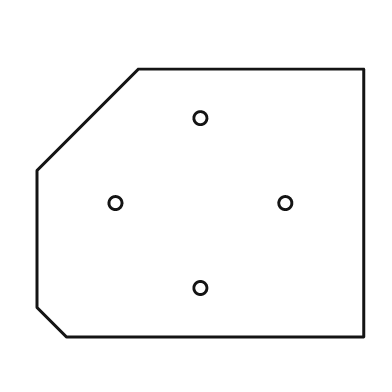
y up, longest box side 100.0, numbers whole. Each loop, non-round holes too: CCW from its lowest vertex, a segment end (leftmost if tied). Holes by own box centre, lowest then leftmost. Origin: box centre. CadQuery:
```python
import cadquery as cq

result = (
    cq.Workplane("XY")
    .moveTo(-41.0, -41.0)
    .lineTo(50.0, -41.0)
    .lineTo(50.0, 41.0)
    .lineTo(-19.0, 41.0)
    .lineTo(-50.0, 10.0)
    .lineTo(-50.0, -32.0)
    .close()
    .moveTo(0.0, -26.0)
    .circle(2.0)
    .moveTo(-26.0, 0.0)
    .circle(2.0)
    .moveTo(26.0, 0.0)
    .circle(2.0)
    .moveTo(0.0, 26.0)
    .circle(2.0)
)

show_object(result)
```